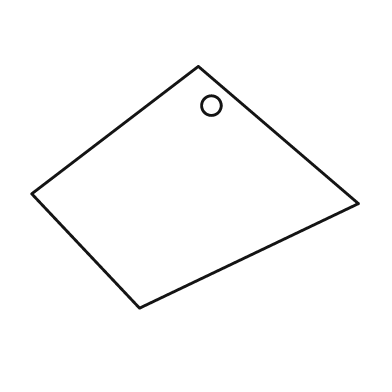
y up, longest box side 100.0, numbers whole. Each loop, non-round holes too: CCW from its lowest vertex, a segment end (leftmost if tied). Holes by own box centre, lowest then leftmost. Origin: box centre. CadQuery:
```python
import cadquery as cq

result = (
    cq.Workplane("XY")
    .moveTo(-17.0, -37.0)
    .lineTo(50.0, -5.0)
    .lineTo(1.0, 37.0)
    .lineTo(-50.0, -2.0)
    .close()
    .moveTo(5.0, 25.0)
    .circle(3.0)
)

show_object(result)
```